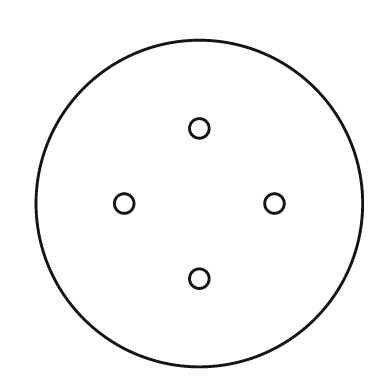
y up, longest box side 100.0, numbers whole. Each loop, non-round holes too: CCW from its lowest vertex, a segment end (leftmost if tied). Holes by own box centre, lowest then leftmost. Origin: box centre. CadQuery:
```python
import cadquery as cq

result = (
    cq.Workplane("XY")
    .moveTo(0.0, 0.0)
    .circle(50.0)
    .moveTo(0.0, -23.0)
    .circle(3.0)
    .moveTo(-23.0, 0.0)
    .circle(3.0)
    .moveTo(23.0, 0.0)
    .circle(3.0)
    .moveTo(0.0, 23.0)
    .circle(3.0)
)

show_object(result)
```